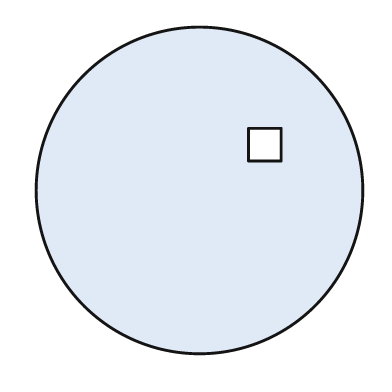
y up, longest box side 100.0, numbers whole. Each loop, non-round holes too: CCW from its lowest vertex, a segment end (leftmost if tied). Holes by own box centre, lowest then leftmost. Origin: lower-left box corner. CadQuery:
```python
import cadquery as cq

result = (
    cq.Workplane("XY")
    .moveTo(50.0, 50.0)
    .circle(50.0)
    .moveTo(65.0, 59.0)
    .lineTo(75.0, 59.0)
    .lineTo(75.0, 69.0)
    .lineTo(65.0, 69.0)
    .close()
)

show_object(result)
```